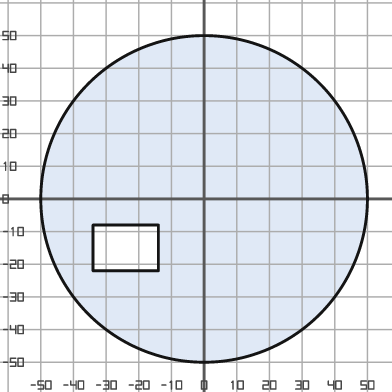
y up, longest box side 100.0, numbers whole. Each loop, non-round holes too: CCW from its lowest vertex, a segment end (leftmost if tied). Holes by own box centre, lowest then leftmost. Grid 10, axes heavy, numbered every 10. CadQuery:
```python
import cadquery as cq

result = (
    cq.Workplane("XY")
    .moveTo(0.0, 0.0)
    .circle(50.0)
    .moveTo(-34.0, -22.0)
    .lineTo(-14.0, -22.0)
    .lineTo(-14.0, -8.0)
    .lineTo(-34.0, -8.0)
    .close()
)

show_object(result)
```